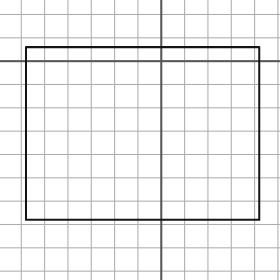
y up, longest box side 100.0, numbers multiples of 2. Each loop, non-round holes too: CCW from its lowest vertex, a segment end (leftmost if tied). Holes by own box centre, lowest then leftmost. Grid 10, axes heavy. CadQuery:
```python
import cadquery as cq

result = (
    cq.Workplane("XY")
    .moveTo(-58.0, -68.0)
    .lineTo(42.0, -68.0)
    .lineTo(42.0, 6.0)
    .lineTo(-58.0, 6.0)
    .close()
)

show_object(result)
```